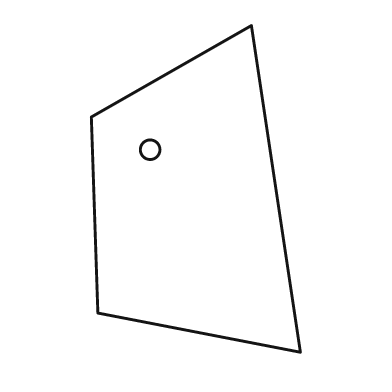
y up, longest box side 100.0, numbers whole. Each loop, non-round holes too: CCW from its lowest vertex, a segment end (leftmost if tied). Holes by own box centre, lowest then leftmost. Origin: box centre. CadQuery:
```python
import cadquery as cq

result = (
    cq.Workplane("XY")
    .moveTo(32.0, -50.0)
    .lineTo(17.0, 50.0)
    .lineTo(-32.0, 22.0)
    .lineTo(-30.0, -38.0)
    .close()
    .moveTo(-14.0, 12.0)
    .circle(3.0)
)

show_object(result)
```